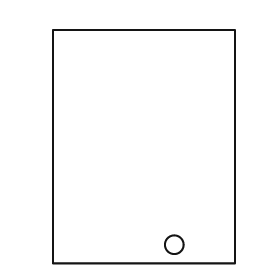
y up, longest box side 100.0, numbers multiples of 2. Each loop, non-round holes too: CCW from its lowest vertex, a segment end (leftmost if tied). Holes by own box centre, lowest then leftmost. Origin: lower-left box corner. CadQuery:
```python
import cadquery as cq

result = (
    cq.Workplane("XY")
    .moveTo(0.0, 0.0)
    .lineTo(78.0, 0.0)
    .lineTo(78.0, 100.0)
    .lineTo(0.0, 100.0)
    .close()
    .moveTo(52.0, 8.0)
    .circle(4.0)
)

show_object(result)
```